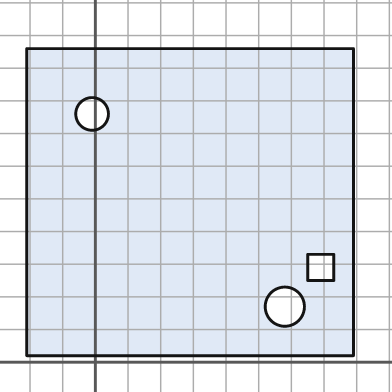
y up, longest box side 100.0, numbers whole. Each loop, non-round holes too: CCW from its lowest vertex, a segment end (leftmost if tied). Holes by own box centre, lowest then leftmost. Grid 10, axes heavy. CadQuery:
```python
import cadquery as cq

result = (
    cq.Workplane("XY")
    .moveTo(-21.0, 2.0)
    .lineTo(79.0, 2.0)
    .lineTo(79.0, 96.0)
    .lineTo(-21.0, 96.0)
    .close()
    .moveTo(58.0, 17.0)
    .circle(6.0)
    .moveTo(65.0, 25.0)
    .lineTo(73.0, 25.0)
    .lineTo(73.0, 33.0)
    .lineTo(65.0, 33.0)
    .close()
    .moveTo(-1.0, 76.0)
    .circle(5.0)
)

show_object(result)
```